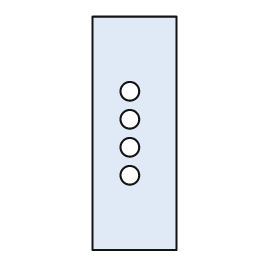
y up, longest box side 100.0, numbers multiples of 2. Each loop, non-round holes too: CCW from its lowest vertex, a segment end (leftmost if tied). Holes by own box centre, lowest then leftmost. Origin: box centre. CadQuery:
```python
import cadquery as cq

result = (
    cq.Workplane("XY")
    .moveTo(-18.0, -50.0)
    .lineTo(18.0, -50.0)
    .lineTo(18.0, 50.0)
    .lineTo(-18.0, 50.0)
    .close()
    .moveTo(-2.0, -18.0)
    .circle(4.0)
    .moveTo(-2.0, -6.0)
    .circle(4.0)
    .moveTo(-2.0, 6.0)
    .circle(4.0)
    .moveTo(-2.0, 18.0)
    .circle(4.0)
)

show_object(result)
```